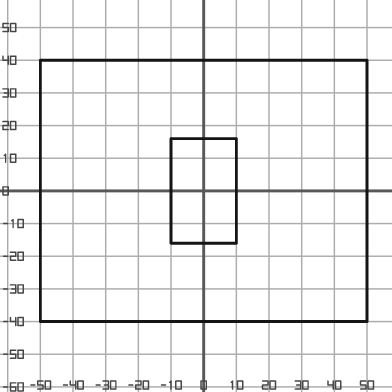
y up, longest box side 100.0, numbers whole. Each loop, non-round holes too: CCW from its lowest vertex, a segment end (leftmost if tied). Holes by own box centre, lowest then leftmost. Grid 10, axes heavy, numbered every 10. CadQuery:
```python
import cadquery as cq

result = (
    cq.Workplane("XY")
    .moveTo(-50.0, -40.0)
    .lineTo(50.0, -40.0)
    .lineTo(50.0, 40.0)
    .lineTo(-50.0, 40.0)
    .close()
    .moveTo(-10.0, -16.0)
    .lineTo(10.0, -16.0)
    .lineTo(10.0, 16.0)
    .lineTo(-10.0, 16.0)
    .close()
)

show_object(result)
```